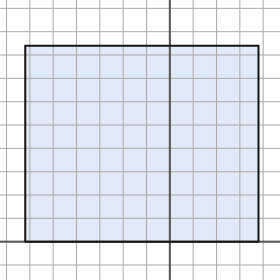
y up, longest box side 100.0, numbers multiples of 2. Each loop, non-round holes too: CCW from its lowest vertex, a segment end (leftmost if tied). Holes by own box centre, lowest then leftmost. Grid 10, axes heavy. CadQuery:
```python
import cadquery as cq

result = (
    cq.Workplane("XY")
    .moveTo(-62.0, 0.0)
    .lineTo(38.0, 0.0)
    .lineTo(38.0, 84.0)
    .lineTo(-62.0, 84.0)
    .close()
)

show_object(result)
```